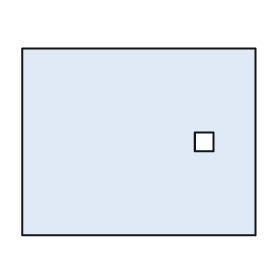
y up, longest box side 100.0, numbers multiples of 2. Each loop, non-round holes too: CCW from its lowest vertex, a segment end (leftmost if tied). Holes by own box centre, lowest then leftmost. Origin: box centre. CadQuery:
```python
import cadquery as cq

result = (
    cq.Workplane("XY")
    .moveTo(-50.0, -40.0)
    .lineTo(50.0, -40.0)
    .lineTo(50.0, 40.0)
    .lineTo(-50.0, 40.0)
    .close()
    .moveTo(24.0, -4.0)
    .lineTo(32.0, -4.0)
    .lineTo(32.0, 4.0)
    .lineTo(24.0, 4.0)
    .close()
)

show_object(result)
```